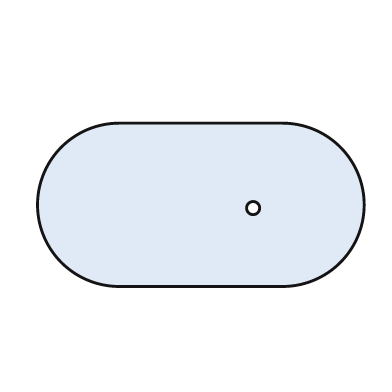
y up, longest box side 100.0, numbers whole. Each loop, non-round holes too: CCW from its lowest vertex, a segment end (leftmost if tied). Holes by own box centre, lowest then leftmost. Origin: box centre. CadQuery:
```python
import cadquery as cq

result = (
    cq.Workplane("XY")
    .moveTo(-25.0, -25.0)
    .lineTo(25.0, -25.0)
    .threePointArc((50.0, 0.0), (25.0, 25.0))
    .lineTo(-25.0, 25.0)
    .threePointArc((-50.0, 0.0), (-25.0, -25.0))
    .close()
    .moveTo(16.0, -1.0)
    .circle(2.0)
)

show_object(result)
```